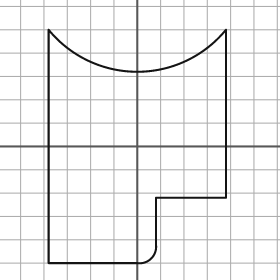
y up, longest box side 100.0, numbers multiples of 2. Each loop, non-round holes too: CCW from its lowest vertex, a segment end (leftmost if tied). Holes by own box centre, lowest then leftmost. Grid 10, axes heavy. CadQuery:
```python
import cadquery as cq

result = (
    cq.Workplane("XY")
    .moveTo(-38.0, -50.0)
    .lineTo(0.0, -50.0)
    .threePointArc((6.0, -48.0), (8.0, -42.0))
    .lineTo(8.0, -22.0)
    .lineTo(38.0, -22.0)
    .lineTo(38.0, 50.0)
    .threePointArc((0.0, 32.0), (-38.0, 50.0))
    .close()
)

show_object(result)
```